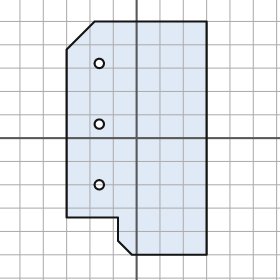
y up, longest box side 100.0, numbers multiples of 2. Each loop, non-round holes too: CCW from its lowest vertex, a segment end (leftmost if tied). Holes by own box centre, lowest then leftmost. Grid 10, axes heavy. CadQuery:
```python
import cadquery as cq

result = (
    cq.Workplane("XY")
    .moveTo(-2.0, -50.0)
    .lineTo(30.0, -50.0)
    .lineTo(30.0, 50.0)
    .lineTo(-18.0, 50.0)
    .lineTo(-30.0, 38.0)
    .lineTo(-30.0, -34.0)
    .lineTo(-8.0, -34.0)
    .lineTo(-8.0, -44.0)
    .close()
    .moveTo(-16.0, -20.0)
    .circle(2.0)
    .moveTo(-16.0, 6.0)
    .circle(2.0)
    .moveTo(-16.0, 32.0)
    .circle(2.0)
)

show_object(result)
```